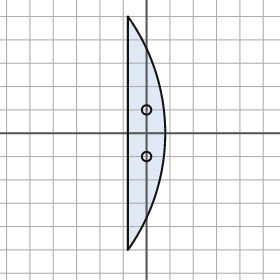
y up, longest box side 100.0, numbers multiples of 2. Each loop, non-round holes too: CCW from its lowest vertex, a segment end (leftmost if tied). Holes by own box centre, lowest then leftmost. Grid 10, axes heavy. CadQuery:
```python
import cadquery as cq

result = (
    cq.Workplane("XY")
    .moveTo(-8.0, -50.0)
    .threePointArc((8.0, 0.0), (-8.0, 50.0))
    .close()
    .moveTo(0.0, -10.0)
    .circle(2.0)
    .moveTo(0.0, 10.0)
    .circle(2.0)
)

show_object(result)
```